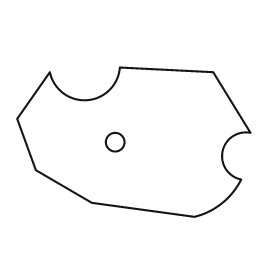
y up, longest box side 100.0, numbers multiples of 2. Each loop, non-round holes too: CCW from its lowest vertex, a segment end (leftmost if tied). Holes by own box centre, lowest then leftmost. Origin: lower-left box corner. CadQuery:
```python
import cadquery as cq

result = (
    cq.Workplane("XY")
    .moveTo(76.0, 0.0)
    .threePointArc((88.0, 6.0), (96.0, 16.0))
    .threePointArc((88.0, 28.0), (100.0, 36.0))
    .lineTo(84.0, 62.0)
    .lineTo(44.0, 64.0)
    .threePointArc((30.0, 50.0), (14.0, 62.0))
    .lineTo(0.0, 42.0)
    .lineTo(8.0, 20.0)
    .lineTo(32.0, 6.0)
    .close()
    .moveTo(42.0, 32.0)
    .circle(4.0)
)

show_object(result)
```